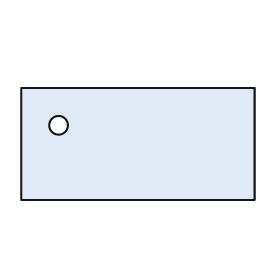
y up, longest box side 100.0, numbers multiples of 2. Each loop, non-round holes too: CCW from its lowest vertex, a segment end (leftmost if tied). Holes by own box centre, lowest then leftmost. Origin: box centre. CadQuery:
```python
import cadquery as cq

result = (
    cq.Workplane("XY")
    .moveTo(-50.0, -24.0)
    .lineTo(50.0, -24.0)
    .lineTo(50.0, 24.0)
    .lineTo(-50.0, 24.0)
    .close()
    .moveTo(-34.0, 8.0)
    .circle(4.0)
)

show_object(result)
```